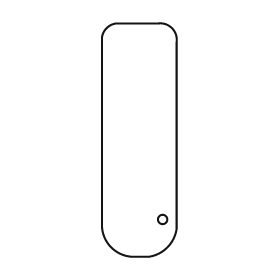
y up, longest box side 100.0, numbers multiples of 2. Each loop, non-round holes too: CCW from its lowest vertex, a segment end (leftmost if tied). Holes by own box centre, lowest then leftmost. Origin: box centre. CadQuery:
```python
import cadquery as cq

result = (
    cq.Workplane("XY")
    .moveTo(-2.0, -50.0)
    .lineTo(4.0, -50.0)
    .threePointArc((12.0, -46.0), (16.0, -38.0))
    .lineTo(16.0, 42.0)
    .threePointArc((14.0, 48.0), (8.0, 50.0))
    .lineTo(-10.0, 50.0)
    .threePointArc((-14.0, 48.0), (-16.0, 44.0))
    .lineTo(-16.0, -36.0)
    .threePointArc((-12.0, -46.0), (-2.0, -50.0))
    .close()
    .moveTo(10.0, -34.0)
    .circle(2.0)
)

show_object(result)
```